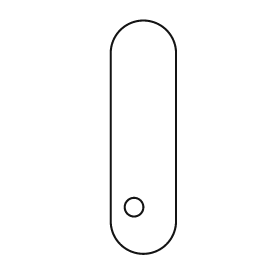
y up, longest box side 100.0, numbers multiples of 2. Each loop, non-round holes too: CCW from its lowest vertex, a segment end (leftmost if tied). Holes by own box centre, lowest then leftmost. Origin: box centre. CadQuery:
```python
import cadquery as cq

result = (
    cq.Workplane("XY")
    .moveTo(-14.0, -36.0)
    .threePointArc((0.0, -50.0), (14.0, -36.0))
    .lineTo(14.0, 36.0)
    .threePointArc((0.0, 50.0), (-14.0, 36.0))
    .close()
    .moveTo(-4.0, -30.0)
    .circle(4.0)
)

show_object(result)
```